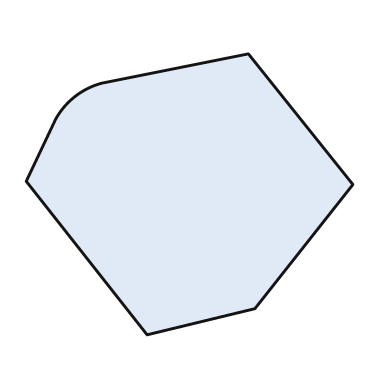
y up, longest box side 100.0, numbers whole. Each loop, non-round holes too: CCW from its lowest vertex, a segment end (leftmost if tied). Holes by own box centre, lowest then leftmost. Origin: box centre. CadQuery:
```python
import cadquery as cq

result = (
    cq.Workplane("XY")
    .moveTo(-13.0, -43.0)
    .lineTo(20.0, -35.0)
    .lineTo(50.0, 3.0)
    .lineTo(18.0, 43.0)
    .lineTo(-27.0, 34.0)
    .threePointArc((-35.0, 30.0), (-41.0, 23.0))
    .lineTo(-50.0, 4.0)
    .close()
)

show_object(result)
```